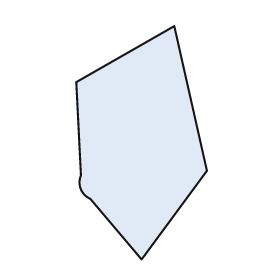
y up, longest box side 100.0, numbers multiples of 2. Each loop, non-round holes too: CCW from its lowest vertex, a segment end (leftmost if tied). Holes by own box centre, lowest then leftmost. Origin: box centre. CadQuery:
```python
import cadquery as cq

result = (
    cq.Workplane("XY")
    .moveTo(0.0, -50.0)
    .lineTo(28.0, -12.0)
    .lineTo(14.0, 50.0)
    .lineTo(-28.0, 26.0)
    .lineTo(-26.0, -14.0)
    .threePointArc((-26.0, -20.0), (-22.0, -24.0))
    .close()
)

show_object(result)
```